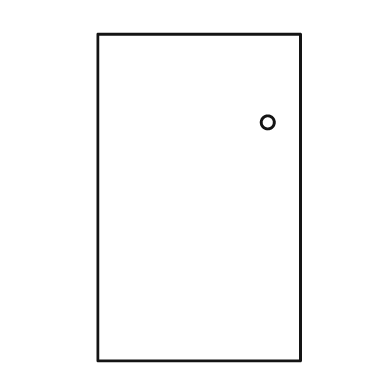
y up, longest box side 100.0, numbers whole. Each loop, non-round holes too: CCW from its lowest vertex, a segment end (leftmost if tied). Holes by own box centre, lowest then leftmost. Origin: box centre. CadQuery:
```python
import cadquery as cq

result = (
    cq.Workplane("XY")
    .moveTo(-31.0, -50.0)
    .lineTo(31.0, -50.0)
    .lineTo(31.0, 50.0)
    .lineTo(-31.0, 50.0)
    .close()
    .moveTo(21.0, 23.0)
    .circle(2.0)
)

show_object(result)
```